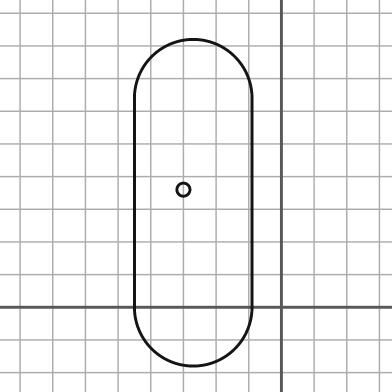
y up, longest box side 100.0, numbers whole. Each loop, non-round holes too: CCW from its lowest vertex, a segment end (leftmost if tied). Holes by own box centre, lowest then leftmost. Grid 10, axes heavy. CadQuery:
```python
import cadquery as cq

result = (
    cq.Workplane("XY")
    .moveTo(-45.0, 0.0)
    .threePointArc((-27.0, -18.0), (-9.0, 0.0))
    .lineTo(-9.0, 64.0)
    .threePointArc((-27.0, 82.0), (-45.0, 64.0))
    .close()
    .moveTo(-30.0, 36.0)
    .circle(2.0)
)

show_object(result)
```